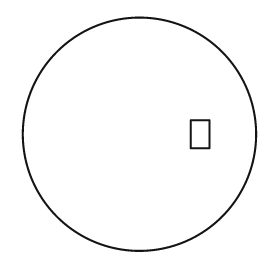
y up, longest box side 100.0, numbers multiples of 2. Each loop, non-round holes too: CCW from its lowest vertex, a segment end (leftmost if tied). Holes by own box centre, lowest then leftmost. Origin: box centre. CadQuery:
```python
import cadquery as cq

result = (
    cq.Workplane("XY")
    .moveTo(0.0, 0.0)
    .circle(50.0)
    .moveTo(22.0, -6.0)
    .lineTo(30.0, -6.0)
    .lineTo(30.0, 6.0)
    .lineTo(22.0, 6.0)
    .close()
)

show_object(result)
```